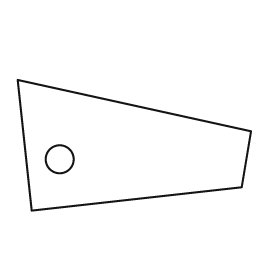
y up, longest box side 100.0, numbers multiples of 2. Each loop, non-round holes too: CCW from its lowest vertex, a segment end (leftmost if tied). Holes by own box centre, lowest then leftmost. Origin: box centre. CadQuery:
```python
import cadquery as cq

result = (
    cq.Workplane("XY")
    .moveTo(-44.0, -28.0)
    .lineTo(46.0, -18.0)
    .lineTo(50.0, 6.0)
    .lineTo(-50.0, 28.0)
    .close()
    .moveTo(-32.0, -6.0)
    .circle(6.0)
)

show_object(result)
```